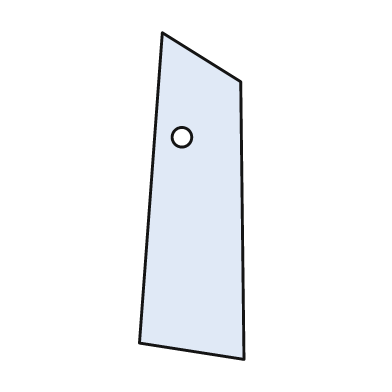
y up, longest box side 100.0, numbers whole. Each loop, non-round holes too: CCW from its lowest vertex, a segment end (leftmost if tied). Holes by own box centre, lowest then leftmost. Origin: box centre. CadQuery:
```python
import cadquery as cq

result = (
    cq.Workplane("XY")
    .moveTo(16.0, -50.0)
    .lineTo(15.0, 35.0)
    .lineTo(-9.0, 50.0)
    .lineTo(-16.0, -45.0)
    .close()
    .moveTo(-3.0, 18.0)
    .circle(3.0)
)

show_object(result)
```